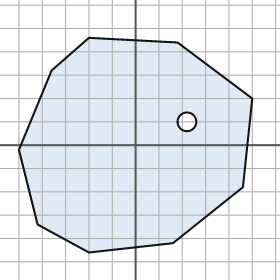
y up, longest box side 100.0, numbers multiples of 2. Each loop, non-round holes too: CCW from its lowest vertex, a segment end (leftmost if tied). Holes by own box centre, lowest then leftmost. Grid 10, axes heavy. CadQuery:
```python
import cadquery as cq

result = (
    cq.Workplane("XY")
    .moveTo(-20.0, -46.0)
    .lineTo(16.0, -42.0)
    .lineTo(46.0, -18.0)
    .lineTo(50.0, 20.0)
    .lineTo(18.0, 44.0)
    .lineTo(-20.0, 46.0)
    .lineTo(-36.0, 32.0)
    .lineTo(-50.0, -2.0)
    .lineTo(-42.0, -34.0)
    .close()
    .moveTo(22.0, 10.0)
    .circle(4.0)
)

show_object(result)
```